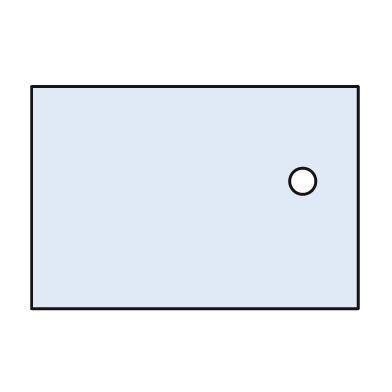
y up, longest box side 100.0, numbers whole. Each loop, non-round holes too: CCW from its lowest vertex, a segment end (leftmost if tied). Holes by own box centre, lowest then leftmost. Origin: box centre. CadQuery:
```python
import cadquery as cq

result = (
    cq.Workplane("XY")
    .moveTo(-50.0, -34.0)
    .lineTo(50.0, -34.0)
    .lineTo(50.0, 34.0)
    .lineTo(-50.0, 34.0)
    .close()
    .moveTo(33.0, 5.0)
    .circle(4.0)
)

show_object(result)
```